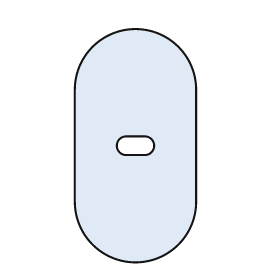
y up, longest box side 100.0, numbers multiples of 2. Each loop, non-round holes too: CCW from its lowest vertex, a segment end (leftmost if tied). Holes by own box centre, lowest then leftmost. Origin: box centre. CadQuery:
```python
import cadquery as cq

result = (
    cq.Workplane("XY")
    .moveTo(-26.0, -24.0)
    .threePointArc((0.0, -50.0), (26.0, -24.0))
    .lineTo(26.0, 24.0)
    .threePointArc((0.0, 50.0), (-26.0, 24.0))
    .close()
    .moveTo(-4.0, -4.0)
    .lineTo(4.0, -4.0)
    .threePointArc((8.0, 0.0), (4.0, 4.0))
    .lineTo(-4.0, 4.0)
    .threePointArc((-8.0, 0.0), (-4.0, -4.0))
    .close()
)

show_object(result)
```